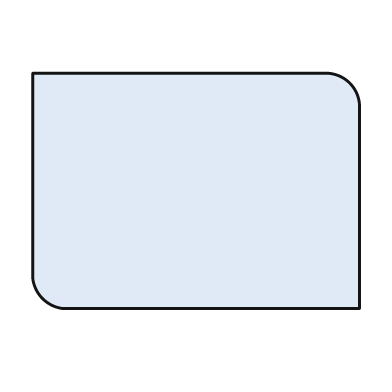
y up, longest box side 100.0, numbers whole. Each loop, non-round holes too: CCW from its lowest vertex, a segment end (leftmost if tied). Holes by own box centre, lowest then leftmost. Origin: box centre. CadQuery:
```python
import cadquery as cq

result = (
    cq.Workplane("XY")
    .moveTo(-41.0, -36.0)
    .lineTo(50.0, -36.0)
    .lineTo(50.0, 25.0)
    .threePointArc((47.0, 33.0), (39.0, 36.0))
    .lineTo(-50.0, 36.0)
    .lineTo(-50.0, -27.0)
    .threePointArc((-47.0, -33.0), (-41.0, -36.0))
    .close()
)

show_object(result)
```